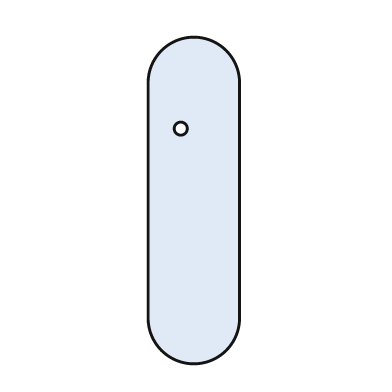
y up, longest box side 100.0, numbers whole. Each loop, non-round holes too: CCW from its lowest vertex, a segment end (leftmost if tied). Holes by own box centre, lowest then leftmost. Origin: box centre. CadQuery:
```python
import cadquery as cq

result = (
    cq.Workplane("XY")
    .moveTo(-14.0, -36.0)
    .threePointArc((0.0, -50.0), (14.0, -36.0))
    .lineTo(14.0, 36.0)
    .threePointArc((0.0, 50.0), (-14.0, 36.0))
    .close()
    .moveTo(-4.0, 22.0)
    .circle(2.0)
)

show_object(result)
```